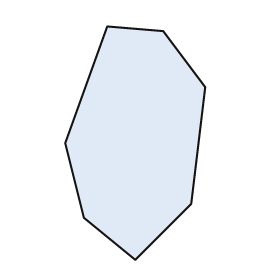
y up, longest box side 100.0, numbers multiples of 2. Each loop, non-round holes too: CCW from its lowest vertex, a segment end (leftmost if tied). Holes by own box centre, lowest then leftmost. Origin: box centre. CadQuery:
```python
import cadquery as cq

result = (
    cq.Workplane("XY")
    .moveTo(0.0, -50.0)
    .lineTo(24.0, -26.0)
    .lineTo(30.0, 24.0)
    .lineTo(12.0, 48.0)
    .lineTo(-12.0, 50.0)
    .lineTo(-30.0, 0.0)
    .lineTo(-22.0, -32.0)
    .close()
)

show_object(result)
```